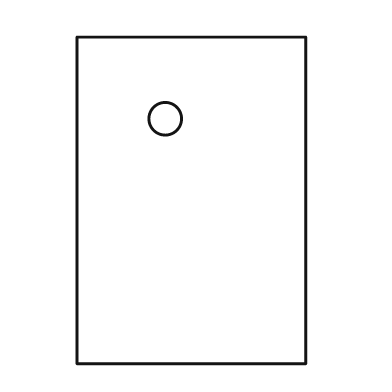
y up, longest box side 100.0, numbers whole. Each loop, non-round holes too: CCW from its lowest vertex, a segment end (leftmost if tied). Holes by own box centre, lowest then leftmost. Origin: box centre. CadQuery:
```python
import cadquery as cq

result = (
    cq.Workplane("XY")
    .moveTo(-35.0, -50.0)
    .lineTo(35.0, -50.0)
    .lineTo(35.0, 50.0)
    .lineTo(-35.0, 50.0)
    .close()
    .moveTo(-8.0, 25.0)
    .circle(5.0)
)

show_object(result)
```